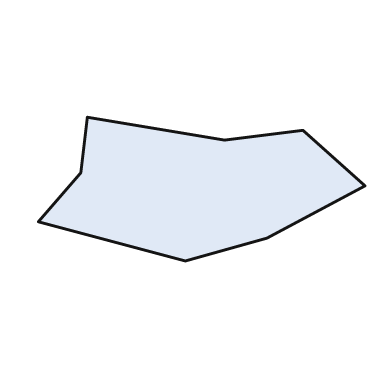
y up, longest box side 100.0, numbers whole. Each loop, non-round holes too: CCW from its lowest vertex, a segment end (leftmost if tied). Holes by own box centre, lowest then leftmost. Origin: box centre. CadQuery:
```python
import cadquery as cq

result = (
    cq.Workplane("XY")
    .moveTo(-5.0, -22.0)
    .lineTo(20.0, -15.0)
    .lineTo(50.0, 1.0)
    .lineTo(31.0, 18.0)
    .lineTo(7.0, 15.0)
    .lineTo(-35.0, 22.0)
    .lineTo(-37.0, 5.0)
    .lineTo(-50.0, -10.0)
    .close()
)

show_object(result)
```